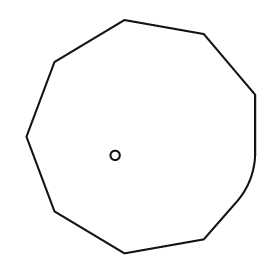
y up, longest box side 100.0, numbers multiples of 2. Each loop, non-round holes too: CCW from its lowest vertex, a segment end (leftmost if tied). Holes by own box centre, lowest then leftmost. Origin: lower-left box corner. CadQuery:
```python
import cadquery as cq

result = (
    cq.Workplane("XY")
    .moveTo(42.0, 0.0)
    .lineTo(76.0, 6.0)
    .lineTo(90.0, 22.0)
    .threePointArc((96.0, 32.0), (98.0, 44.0))
    .lineTo(98.0, 68.0)
    .lineTo(76.0, 94.0)
    .lineTo(42.0, 100.0)
    .lineTo(12.0, 82.0)
    .lineTo(0.0, 50.0)
    .lineTo(12.0, 18.0)
    .close()
    .moveTo(38.0, 42.0)
    .circle(2.0)
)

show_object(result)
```